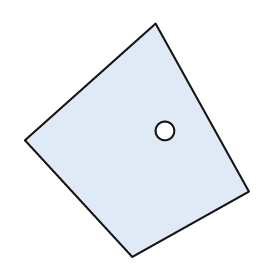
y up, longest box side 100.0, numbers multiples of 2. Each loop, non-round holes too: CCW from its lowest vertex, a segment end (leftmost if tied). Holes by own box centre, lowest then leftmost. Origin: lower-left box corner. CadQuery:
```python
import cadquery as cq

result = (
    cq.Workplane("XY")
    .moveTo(46.0, 0.0)
    .lineTo(96.0, 28.0)
    .lineTo(56.0, 100.0)
    .lineTo(0.0, 50.0)
    .close()
    .moveTo(60.0, 54.0)
    .circle(4.0)
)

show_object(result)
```